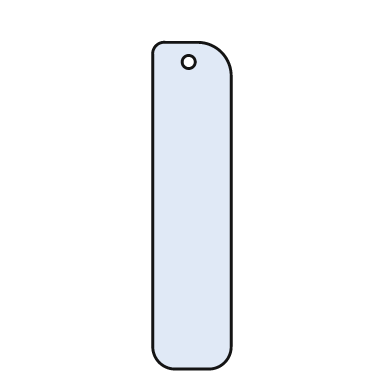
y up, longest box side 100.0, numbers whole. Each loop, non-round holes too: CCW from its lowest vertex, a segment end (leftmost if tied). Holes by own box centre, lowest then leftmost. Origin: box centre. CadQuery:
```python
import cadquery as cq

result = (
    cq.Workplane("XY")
    .moveTo(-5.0, -50.0)
    .lineTo(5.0, -50.0)
    .threePointArc((10.0, -48.0), (12.0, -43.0))
    .lineTo(12.0, 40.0)
    .threePointArc((9.0, 47.0), (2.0, 50.0))
    .lineTo(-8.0, 50.0)
    .threePointArc((-11.0, 49.0), (-12.0, 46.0))
    .lineTo(-12.0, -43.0)
    .threePointArc((-10.0, -48.0), (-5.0, -50.0))
    .close()
    .moveTo(-1.0, 44.0)
    .circle(2.0)
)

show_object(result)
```